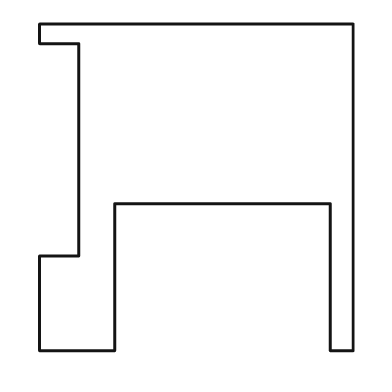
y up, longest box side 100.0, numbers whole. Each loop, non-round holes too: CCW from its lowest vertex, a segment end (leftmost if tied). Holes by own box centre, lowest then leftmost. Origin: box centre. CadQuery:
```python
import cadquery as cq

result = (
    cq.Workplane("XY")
    .moveTo(-48.0, -50.0)
    .lineTo(-25.0, -50.0)
    .lineTo(-25.0, -5.0)
    .lineTo(41.0, -5.0)
    .lineTo(41.0, -50.0)
    .lineTo(48.0, -50.0)
    .lineTo(48.0, 50.0)
    .lineTo(-48.0, 50.0)
    .lineTo(-48.0, 44.0)
    .lineTo(-36.0, 44.0)
    .lineTo(-36.0, -21.0)
    .lineTo(-48.0, -21.0)
    .close()
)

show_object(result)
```